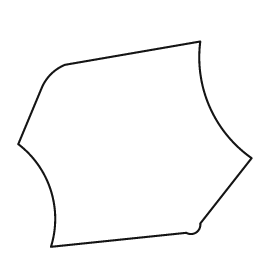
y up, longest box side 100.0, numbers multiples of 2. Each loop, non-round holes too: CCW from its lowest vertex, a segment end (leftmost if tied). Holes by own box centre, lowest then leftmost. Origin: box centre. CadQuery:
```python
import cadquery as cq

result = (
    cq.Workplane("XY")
    .moveTo(-36.0, -44.0)
    .lineTo(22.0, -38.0)
    .threePointArc((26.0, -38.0), (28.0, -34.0))
    .lineTo(50.0, -6.0)
    .threePointArc((32.0, 16.0), (28.0, 44.0))
    .lineTo(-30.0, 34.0)
    .threePointArc((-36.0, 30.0), (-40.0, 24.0))
    .lineTo(-50.0, 0.0)
    .threePointArc((-36.0, -20.0), (-36.0, -44.0))
    .close()
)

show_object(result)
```